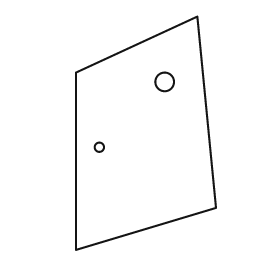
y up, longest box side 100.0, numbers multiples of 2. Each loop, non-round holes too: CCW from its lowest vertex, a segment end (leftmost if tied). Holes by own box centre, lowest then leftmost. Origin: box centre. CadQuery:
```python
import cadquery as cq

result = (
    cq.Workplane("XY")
    .moveTo(-30.0, -50.0)
    .lineTo(30.0, -32.0)
    .lineTo(22.0, 50.0)
    .lineTo(-30.0, 26.0)
    .close()
    .moveTo(-20.0, -6.0)
    .circle(2.0)
    .moveTo(8.0, 22.0)
    .circle(4.0)
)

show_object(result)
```